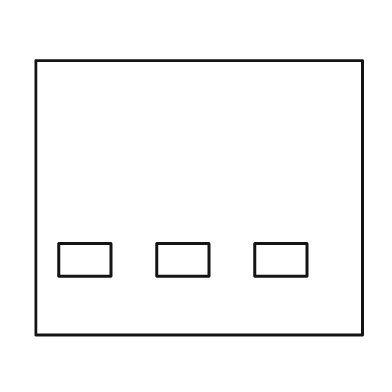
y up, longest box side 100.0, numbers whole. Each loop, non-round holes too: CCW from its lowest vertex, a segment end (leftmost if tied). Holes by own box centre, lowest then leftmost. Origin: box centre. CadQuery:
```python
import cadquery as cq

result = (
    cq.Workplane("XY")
    .moveTo(-50.0, -42.0)
    .lineTo(50.0, -42.0)
    .lineTo(50.0, 42.0)
    .lineTo(-50.0, 42.0)
    .close()
    .moveTo(-43.0, -24.0)
    .lineTo(-27.0, -24.0)
    .lineTo(-27.0, -14.0)
    .lineTo(-43.0, -14.0)
    .close()
    .moveTo(-13.0, -24.0)
    .lineTo(3.0, -24.0)
    .lineTo(3.0, -14.0)
    .lineTo(-13.0, -14.0)
    .close()
    .moveTo(17.0, -24.0)
    .lineTo(33.0, -24.0)
    .lineTo(33.0, -14.0)
    .lineTo(17.0, -14.0)
    .close()
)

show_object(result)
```